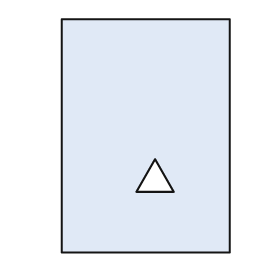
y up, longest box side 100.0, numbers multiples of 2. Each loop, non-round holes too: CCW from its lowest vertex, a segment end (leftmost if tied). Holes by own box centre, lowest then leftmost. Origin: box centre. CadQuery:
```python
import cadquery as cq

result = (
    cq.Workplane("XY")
    .moveTo(-36.0, -50.0)
    .lineTo(36.0, -50.0)
    .lineTo(36.0, 50.0)
    .lineTo(-36.0, 50.0)
    .close()
    .moveTo(-4.0, -24.0)
    .lineTo(12.0, -24.0)
    .lineTo(4.0, -10.0)
    .close()
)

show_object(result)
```